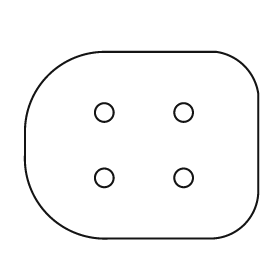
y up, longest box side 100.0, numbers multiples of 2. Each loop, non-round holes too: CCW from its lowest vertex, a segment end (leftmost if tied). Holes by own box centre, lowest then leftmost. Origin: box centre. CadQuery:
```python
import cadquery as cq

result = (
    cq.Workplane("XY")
    .moveTo(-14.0, -40.0)
    .lineTo(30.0, -40.0)
    .threePointArc((44.0, -34.0), (50.0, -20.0))
    .lineTo(50.0, 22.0)
    .threePointArc((44.0, 34.0), (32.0, 40.0))
    .lineTo(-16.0, 40.0)
    .threePointArc((-40.0, 30.0), (-50.0, 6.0))
    .lineTo(-50.0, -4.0)
    .threePointArc((-40.0, -30.0), (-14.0, -40.0))
    .close()
    .moveTo(-16.0, -14.0)
    .circle(4.0)
    .moveTo(18.0, -14.0)
    .circle(4.0)
    .moveTo(-16.0, 14.0)
    .circle(4.0)
    .moveTo(18.0, 14.0)
    .circle(4.0)
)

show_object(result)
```